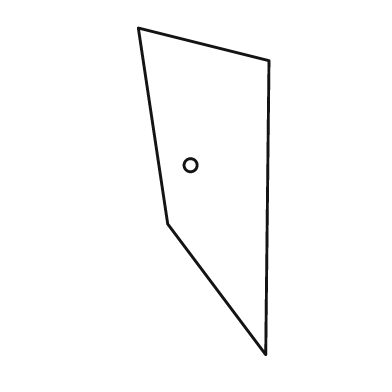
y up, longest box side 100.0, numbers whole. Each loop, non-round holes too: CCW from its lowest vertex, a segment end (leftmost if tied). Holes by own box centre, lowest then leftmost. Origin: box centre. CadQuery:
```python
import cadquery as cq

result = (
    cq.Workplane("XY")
    .moveTo(19.0, -50.0)
    .lineTo(20.0, 40.0)
    .lineTo(-20.0, 50.0)
    .lineTo(-11.0, -10.0)
    .close()
    .moveTo(-4.0, 8.0)
    .circle(2.0)
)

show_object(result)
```